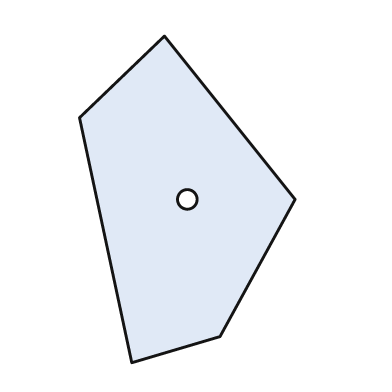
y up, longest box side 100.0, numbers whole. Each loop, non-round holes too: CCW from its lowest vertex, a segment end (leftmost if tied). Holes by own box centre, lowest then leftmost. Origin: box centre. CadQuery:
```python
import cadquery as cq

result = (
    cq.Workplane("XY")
    .moveTo(-17.0, -50.0)
    .lineTo(10.0, -42.0)
    .lineTo(33.0, 0.0)
    .lineTo(-7.0, 50.0)
    .lineTo(-33.0, 25.0)
    .close()
    .moveTo(0.0, 0.0)
    .circle(3.0)
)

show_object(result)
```